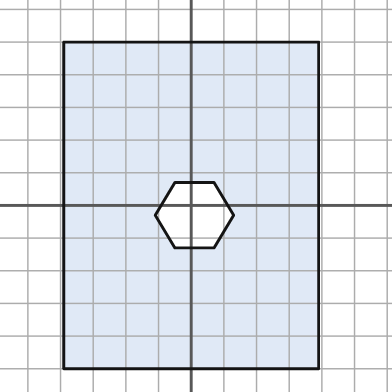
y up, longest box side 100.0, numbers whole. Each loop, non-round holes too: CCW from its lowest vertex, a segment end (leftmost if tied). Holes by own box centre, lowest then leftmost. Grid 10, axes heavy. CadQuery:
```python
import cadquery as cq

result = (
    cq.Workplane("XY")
    .moveTo(-39.0, -50.0)
    .lineTo(39.0, -50.0)
    .lineTo(39.0, 50.0)
    .lineTo(-39.0, 50.0)
    .close()
    .moveTo(-5.0, -13.0)
    .lineTo(7.0, -13.0)
    .lineTo(13.0, -3.0)
    .lineTo(7.0, 7.0)
    .lineTo(-5.0, 7.0)
    .lineTo(-11.0, -3.0)
    .close()
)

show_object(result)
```